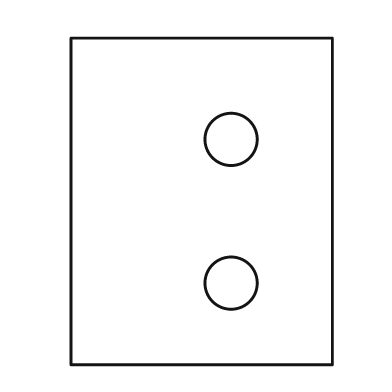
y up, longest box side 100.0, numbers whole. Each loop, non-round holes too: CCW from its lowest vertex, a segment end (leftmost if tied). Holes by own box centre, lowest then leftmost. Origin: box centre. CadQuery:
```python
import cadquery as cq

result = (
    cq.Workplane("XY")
    .moveTo(-40.0, -50.0)
    .lineTo(40.0, -50.0)
    .lineTo(40.0, 50.0)
    .lineTo(-40.0, 50.0)
    .close()
    .moveTo(9.0, -25.0)
    .circle(8.0)
    .moveTo(9.0, 19.0)
    .circle(8.0)
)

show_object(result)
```